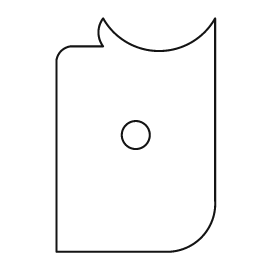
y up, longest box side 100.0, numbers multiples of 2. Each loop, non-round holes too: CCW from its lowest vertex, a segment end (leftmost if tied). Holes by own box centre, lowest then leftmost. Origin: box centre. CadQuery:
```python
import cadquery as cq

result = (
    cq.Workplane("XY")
    .moveTo(-34.0, -50.0)
    .lineTo(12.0, -50.0)
    .threePointArc((28.0, -44.0), (34.0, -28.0))
    .lineTo(34.0, 50.0)
    .threePointArc((10.0, 36.0), (-14.0, 50.0))
    .threePointArc((-16.0, 44.0), (-14.0, 38.0))
    .lineTo(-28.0, 38.0)
    .threePointArc((-32.0, 36.0), (-34.0, 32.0))
    .close()
    .moveTo(0.0, 0.0)
    .circle(6.0)
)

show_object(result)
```